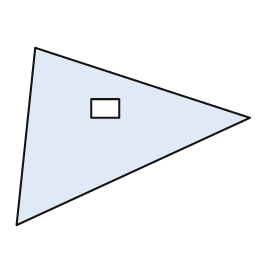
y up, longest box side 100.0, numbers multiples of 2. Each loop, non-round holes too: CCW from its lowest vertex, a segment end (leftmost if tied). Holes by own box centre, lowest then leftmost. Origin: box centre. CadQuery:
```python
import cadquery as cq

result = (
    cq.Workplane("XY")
    .moveTo(-50.0, -38.0)
    .lineTo(50.0, 8.0)
    .lineTo(-42.0, 38.0)
    .close()
    .moveTo(-18.0, 8.0)
    .lineTo(-6.0, 8.0)
    .lineTo(-6.0, 16.0)
    .lineTo(-18.0, 16.0)
    .close()
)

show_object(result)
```